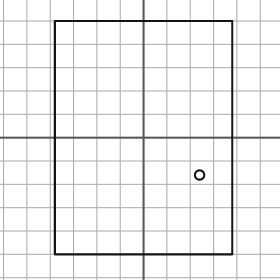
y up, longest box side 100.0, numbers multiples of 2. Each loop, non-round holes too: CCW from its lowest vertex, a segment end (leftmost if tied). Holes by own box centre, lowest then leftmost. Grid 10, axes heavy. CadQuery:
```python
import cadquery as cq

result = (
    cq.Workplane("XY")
    .moveTo(-38.0, -50.0)
    .lineTo(38.0, -50.0)
    .lineTo(38.0, 50.0)
    .lineTo(-38.0, 50.0)
    .close()
    .moveTo(24.0, -16.0)
    .circle(2.0)
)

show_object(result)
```